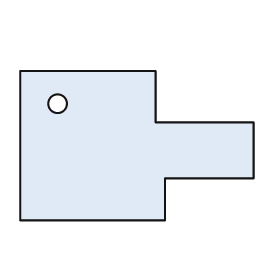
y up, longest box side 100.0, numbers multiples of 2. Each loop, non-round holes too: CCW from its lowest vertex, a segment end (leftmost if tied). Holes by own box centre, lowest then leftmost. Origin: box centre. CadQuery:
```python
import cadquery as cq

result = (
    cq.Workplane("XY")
    .moveTo(-50.0, -32.0)
    .lineTo(12.0, -32.0)
    .lineTo(12.0, -14.0)
    .lineTo(50.0, -14.0)
    .lineTo(50.0, 10.0)
    .lineTo(8.0, 10.0)
    .lineTo(8.0, 32.0)
    .lineTo(-50.0, 32.0)
    .close()
    .moveTo(-34.0, 18.0)
    .circle(4.0)
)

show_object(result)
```